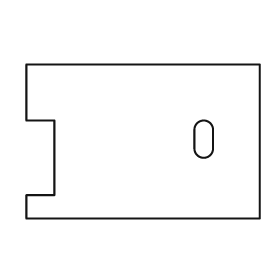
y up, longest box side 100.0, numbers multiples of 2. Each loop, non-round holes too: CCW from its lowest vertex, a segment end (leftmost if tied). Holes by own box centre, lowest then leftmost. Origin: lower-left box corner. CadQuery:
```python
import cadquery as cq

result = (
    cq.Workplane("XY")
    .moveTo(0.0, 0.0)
    .lineTo(100.0, 0.0)
    .lineTo(100.0, 66.0)
    .lineTo(0.0, 66.0)
    .lineTo(0.0, 42.0)
    .lineTo(12.0, 42.0)
    .lineTo(12.0, 10.0)
    .lineTo(0.0, 10.0)
    .close()
    .moveTo(72.0, 30.0)
    .threePointArc((76.0, 26.0), (80.0, 30.0))
    .lineTo(80.0, 38.0)
    .threePointArc((76.0, 42.0), (72.0, 38.0))
    .close()
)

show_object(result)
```